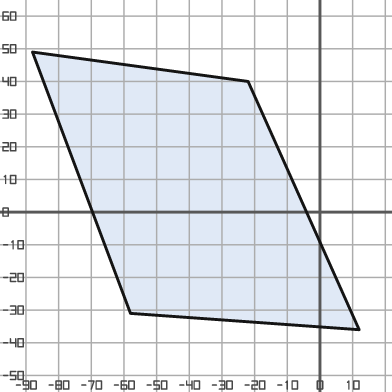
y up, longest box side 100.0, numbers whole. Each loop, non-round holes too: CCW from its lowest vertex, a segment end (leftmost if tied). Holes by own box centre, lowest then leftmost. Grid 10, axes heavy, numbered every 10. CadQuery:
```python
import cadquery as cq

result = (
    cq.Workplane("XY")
    .moveTo(12.0, -36.0)
    .lineTo(-22.0, 40.0)
    .lineTo(-88.0, 49.0)
    .lineTo(-58.0, -31.0)
    .close()
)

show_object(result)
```